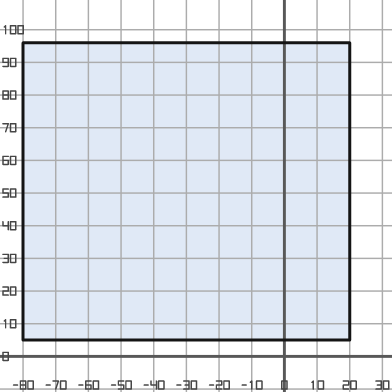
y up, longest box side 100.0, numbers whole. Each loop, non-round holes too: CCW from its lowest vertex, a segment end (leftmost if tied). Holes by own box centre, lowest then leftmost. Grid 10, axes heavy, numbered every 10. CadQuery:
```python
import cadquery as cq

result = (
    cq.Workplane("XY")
    .moveTo(-80.0, 5.0)
    .lineTo(20.0, 5.0)
    .lineTo(20.0, 96.0)
    .lineTo(-80.0, 96.0)
    .close()
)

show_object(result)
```